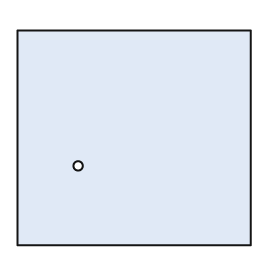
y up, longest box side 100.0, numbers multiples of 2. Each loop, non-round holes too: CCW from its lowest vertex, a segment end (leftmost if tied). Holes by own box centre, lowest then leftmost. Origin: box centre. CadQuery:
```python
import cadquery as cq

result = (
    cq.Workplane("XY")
    .moveTo(-50.0, -46.0)
    .lineTo(50.0, -46.0)
    .lineTo(50.0, 46.0)
    .lineTo(-50.0, 46.0)
    .close()
    .moveTo(-24.0, -12.0)
    .circle(2.0)
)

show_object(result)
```